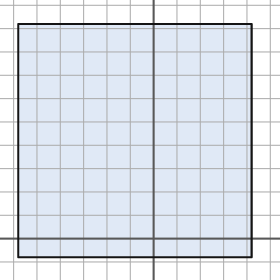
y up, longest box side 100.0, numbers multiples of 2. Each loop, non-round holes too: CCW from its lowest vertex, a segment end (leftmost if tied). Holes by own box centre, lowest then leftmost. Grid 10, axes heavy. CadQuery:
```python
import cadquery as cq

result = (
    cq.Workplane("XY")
    .moveTo(-58.0, -8.0)
    .lineTo(42.0, -8.0)
    .lineTo(42.0, 92.0)
    .lineTo(-58.0, 92.0)
    .close()
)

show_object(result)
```